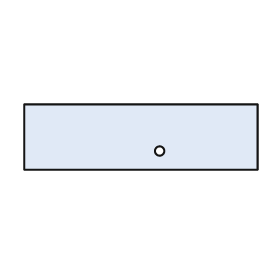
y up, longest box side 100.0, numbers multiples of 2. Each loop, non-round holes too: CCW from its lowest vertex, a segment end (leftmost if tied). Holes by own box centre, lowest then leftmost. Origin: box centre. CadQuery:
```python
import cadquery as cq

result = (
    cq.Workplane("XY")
    .moveTo(-50.0, -14.0)
    .lineTo(50.0, -14.0)
    .lineTo(50.0, 14.0)
    .lineTo(-50.0, 14.0)
    .close()
    .moveTo(8.0, -6.0)
    .circle(2.0)
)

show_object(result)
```